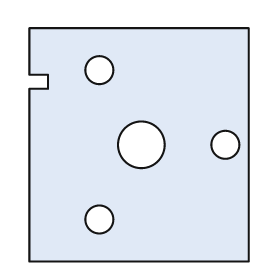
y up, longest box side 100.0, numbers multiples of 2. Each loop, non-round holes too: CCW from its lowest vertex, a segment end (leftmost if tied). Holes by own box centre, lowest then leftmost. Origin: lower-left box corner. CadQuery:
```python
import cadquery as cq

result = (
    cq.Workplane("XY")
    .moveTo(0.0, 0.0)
    .lineTo(94.0, 0.0)
    .lineTo(94.0, 100.0)
    .lineTo(0.0, 100.0)
    .lineTo(0.0, 80.0)
    .lineTo(8.0, 80.0)
    .lineTo(8.0, 74.0)
    .lineTo(0.0, 74.0)
    .close()
    .moveTo(30.0, 18.0)
    .circle(6.0)
    .moveTo(48.0, 50.0)
    .circle(10.0)
    .moveTo(84.0, 50.0)
    .circle(6.0)
    .moveTo(30.0, 82.0)
    .circle(6.0)
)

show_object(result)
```